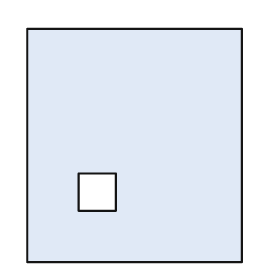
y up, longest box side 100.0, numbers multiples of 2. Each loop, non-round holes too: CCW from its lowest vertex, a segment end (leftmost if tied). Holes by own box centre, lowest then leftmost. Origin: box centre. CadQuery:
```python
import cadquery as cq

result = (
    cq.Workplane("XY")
    .moveTo(-46.0, -50.0)
    .lineTo(46.0, -50.0)
    .lineTo(46.0, 50.0)
    .lineTo(-46.0, 50.0)
    .close()
    .moveTo(-24.0, -28.0)
    .lineTo(-8.0, -28.0)
    .lineTo(-8.0, -12.0)
    .lineTo(-24.0, -12.0)
    .close()
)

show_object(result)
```